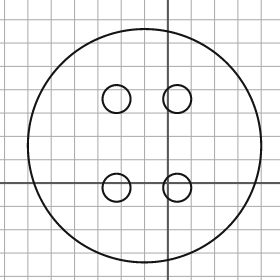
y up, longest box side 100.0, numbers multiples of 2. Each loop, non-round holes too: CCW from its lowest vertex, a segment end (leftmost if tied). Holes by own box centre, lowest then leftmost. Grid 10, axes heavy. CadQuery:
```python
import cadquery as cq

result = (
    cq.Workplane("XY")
    .moveTo(-10.0, 16.0)
    .circle(50.0)
    .moveTo(-22.0, -2.0)
    .circle(6.0)
    .moveTo(4.0, -2.0)
    .circle(6.0)
    .moveTo(-22.0, 36.0)
    .circle(6.0)
    .moveTo(4.0, 36.0)
    .circle(6.0)
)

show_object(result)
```